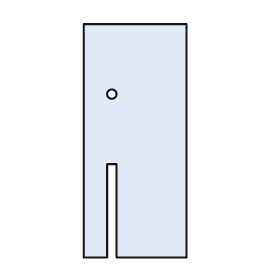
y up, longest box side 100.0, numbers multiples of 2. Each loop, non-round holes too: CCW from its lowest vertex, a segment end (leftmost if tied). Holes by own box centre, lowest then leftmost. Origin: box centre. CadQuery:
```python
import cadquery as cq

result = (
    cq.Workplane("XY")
    .moveTo(-22.0, -50.0)
    .lineTo(-12.0, -50.0)
    .lineTo(-12.0, -10.0)
    .lineTo(-8.0, -10.0)
    .lineTo(-8.0, -50.0)
    .lineTo(22.0, -50.0)
    .lineTo(22.0, 50.0)
    .lineTo(-22.0, 50.0)
    .close()
    .moveTo(-10.0, 20.0)
    .circle(2.0)
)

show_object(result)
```